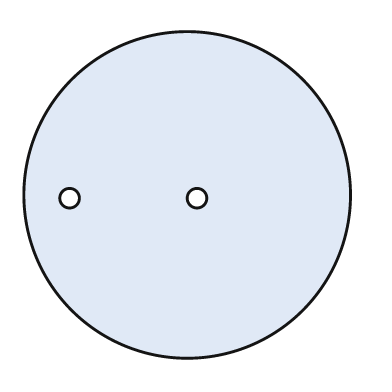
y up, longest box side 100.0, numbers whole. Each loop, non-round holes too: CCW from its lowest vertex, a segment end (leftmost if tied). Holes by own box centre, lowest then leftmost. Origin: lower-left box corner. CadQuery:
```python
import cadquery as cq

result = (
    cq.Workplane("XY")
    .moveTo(50.0, 50.0)
    .circle(50.0)
    .moveTo(14.0, 49.0)
    .circle(3.0)
    .moveTo(53.0, 49.0)
    .circle(3.0)
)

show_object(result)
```